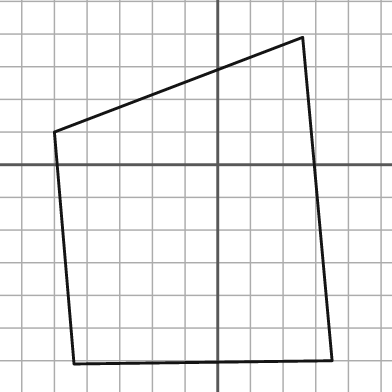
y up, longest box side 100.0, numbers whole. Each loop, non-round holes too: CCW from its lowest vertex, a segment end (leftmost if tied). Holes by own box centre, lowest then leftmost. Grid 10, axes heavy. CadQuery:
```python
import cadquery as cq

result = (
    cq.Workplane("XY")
    .moveTo(-44.0, -61.0)
    .lineTo(35.0, -60.0)
    .lineTo(26.0, 39.0)
    .lineTo(-50.0, 10.0)
    .close()
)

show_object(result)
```